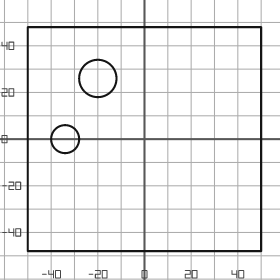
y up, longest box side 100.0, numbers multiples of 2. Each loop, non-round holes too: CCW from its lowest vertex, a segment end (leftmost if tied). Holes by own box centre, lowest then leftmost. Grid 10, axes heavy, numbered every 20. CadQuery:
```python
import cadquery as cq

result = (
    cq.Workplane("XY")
    .moveTo(-50.0, -48.0)
    .lineTo(50.0, -48.0)
    .lineTo(50.0, 48.0)
    .lineTo(-50.0, 48.0)
    .close()
    .moveTo(-34.0, 0.0)
    .circle(6.0)
    .moveTo(-20.0, 26.0)
    .circle(8.0)
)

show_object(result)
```